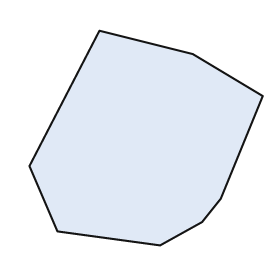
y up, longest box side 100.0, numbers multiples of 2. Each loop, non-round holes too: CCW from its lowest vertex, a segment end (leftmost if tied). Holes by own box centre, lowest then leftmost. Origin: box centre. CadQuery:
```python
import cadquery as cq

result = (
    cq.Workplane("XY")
    .moveTo(6.0, -46.0)
    .lineTo(24.0, -36.0)
    .lineTo(32.0, -26.0)
    .lineTo(50.0, 18.0)
    .lineTo(20.0, 36.0)
    .lineTo(-20.0, 46.0)
    .lineTo(-50.0, -12.0)
    .lineTo(-38.0, -40.0)
    .close()
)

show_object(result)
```